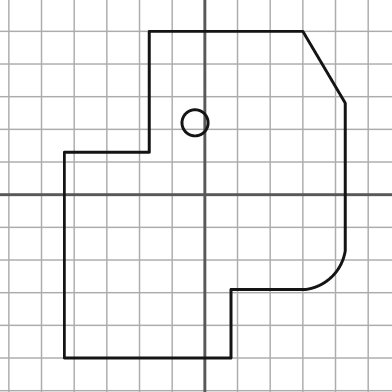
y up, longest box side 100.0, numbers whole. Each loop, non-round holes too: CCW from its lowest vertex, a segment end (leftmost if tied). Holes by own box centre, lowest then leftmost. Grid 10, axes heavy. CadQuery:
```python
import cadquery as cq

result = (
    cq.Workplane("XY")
    .moveTo(-43.0, -50.0)
    .lineTo(8.0, -50.0)
    .lineTo(8.0, -29.0)
    .lineTo(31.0, -29.0)
    .threePointArc((39.0, -25.0), (43.0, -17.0))
    .lineTo(43.0, 28.0)
    .lineTo(30.0, 50.0)
    .lineTo(-17.0, 50.0)
    .lineTo(-17.0, 13.0)
    .lineTo(-43.0, 13.0)
    .close()
    .moveTo(-3.0, 22.0)
    .circle(4.0)
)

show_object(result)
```